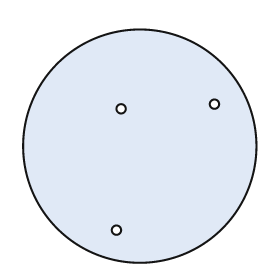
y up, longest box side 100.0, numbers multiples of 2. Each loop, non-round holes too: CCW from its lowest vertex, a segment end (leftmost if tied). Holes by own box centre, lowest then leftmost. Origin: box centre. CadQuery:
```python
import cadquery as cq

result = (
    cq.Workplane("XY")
    .moveTo(0.0, 0.0)
    .circle(50.0)
    .moveTo(-10.0, -36.0)
    .circle(2.0)
    .moveTo(-8.0, 16.0)
    .circle(2.0)
    .moveTo(32.0, 18.0)
    .circle(2.0)
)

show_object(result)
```